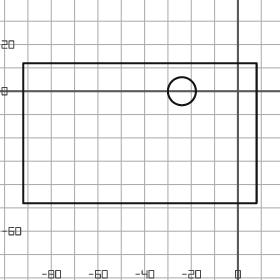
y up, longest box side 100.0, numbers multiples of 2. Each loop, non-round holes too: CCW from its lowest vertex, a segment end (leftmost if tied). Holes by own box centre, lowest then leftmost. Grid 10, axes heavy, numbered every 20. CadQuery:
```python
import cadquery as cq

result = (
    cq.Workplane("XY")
    .moveTo(-92.0, -48.0)
    .lineTo(8.0, -48.0)
    .lineTo(8.0, 12.0)
    .lineTo(-92.0, 12.0)
    .close()
    .moveTo(-24.0, 0.0)
    .circle(6.0)
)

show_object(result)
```